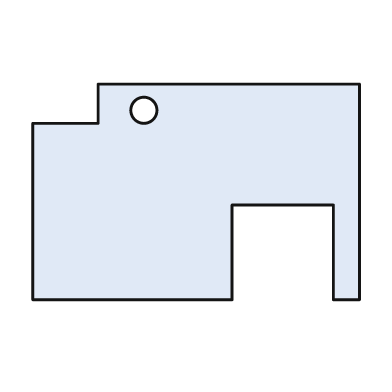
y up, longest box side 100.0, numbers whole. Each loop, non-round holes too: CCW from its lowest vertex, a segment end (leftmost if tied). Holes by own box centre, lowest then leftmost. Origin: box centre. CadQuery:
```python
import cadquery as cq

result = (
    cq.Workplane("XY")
    .moveTo(-50.0, -33.0)
    .lineTo(11.0, -33.0)
    .lineTo(11.0, -4.0)
    .lineTo(42.0, -4.0)
    .lineTo(42.0, -33.0)
    .lineTo(50.0, -33.0)
    .lineTo(50.0, 33.0)
    .lineTo(-30.0, 33.0)
    .lineTo(-30.0, 21.0)
    .lineTo(-50.0, 21.0)
    .close()
    .moveTo(-16.0, 25.0)
    .circle(4.0)
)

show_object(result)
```